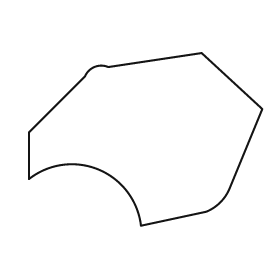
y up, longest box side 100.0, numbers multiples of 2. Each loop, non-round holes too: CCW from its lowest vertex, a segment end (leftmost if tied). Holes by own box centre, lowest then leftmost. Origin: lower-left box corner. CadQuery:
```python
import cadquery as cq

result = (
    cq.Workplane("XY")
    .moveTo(48.0, 0.0)
    .lineTo(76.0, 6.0)
    .threePointArc((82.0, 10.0), (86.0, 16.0))
    .lineTo(100.0, 50.0)
    .lineTo(74.0, 74.0)
    .lineTo(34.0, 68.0)
    .threePointArc((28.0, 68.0), (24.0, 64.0))
    .lineTo(0.0, 40.0)
    .lineTo(0.0, 20.0)
    .threePointArc((30.0, 24.0), (48.0, 0.0))
    .close()
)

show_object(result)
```